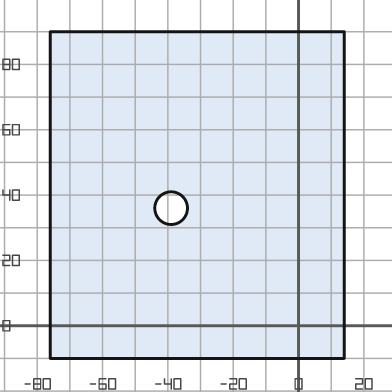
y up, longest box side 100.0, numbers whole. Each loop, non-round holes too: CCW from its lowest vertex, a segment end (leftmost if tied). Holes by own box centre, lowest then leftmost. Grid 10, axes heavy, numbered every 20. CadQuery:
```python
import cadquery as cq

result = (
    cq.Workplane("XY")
    .moveTo(-76.0, -10.0)
    .lineTo(14.0, -10.0)
    .lineTo(14.0, 90.0)
    .lineTo(-76.0, 90.0)
    .close()
    .moveTo(-39.0, 36.0)
    .circle(5.0)
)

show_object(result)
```